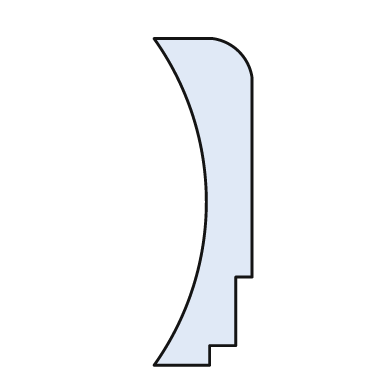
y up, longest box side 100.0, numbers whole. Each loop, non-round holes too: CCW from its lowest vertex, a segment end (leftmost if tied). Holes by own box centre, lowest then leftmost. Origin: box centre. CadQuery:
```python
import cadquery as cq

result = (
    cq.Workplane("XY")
    .moveTo(-15.0, -50.0)
    .lineTo(2.0, -50.0)
    .lineTo(2.0, -44.0)
    .lineTo(10.0, -44.0)
    .lineTo(10.0, -23.0)
    .lineTo(15.0, -23.0)
    .lineTo(15.0, 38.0)
    .threePointArc((11.0, 46.0), (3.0, 50.0))
    .lineTo(-15.0, 50.0)
    .threePointArc((1.0, 0.0), (-15.0, -50.0))
    .close()
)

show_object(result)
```